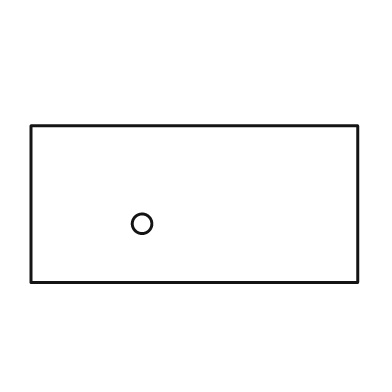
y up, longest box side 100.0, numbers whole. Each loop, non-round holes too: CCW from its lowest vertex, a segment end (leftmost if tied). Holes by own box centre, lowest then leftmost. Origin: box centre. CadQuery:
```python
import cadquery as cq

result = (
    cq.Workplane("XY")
    .moveTo(-50.0, -24.0)
    .lineTo(50.0, -24.0)
    .lineTo(50.0, 24.0)
    .lineTo(-50.0, 24.0)
    .close()
    .moveTo(-16.0, -6.0)
    .circle(3.0)
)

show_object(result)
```